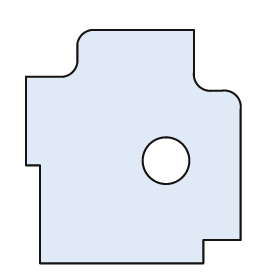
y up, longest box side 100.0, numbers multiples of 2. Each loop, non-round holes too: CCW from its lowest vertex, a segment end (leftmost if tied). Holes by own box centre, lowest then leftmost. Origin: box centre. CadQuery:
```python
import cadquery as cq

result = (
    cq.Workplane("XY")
    .moveTo(-40.0, -50.0)
    .lineTo(30.0, -50.0)
    .lineTo(30.0, -40.0)
    .lineTo(46.0, -40.0)
    .lineTo(46.0, 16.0)
    .threePointArc((44.0, 22.0), (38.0, 24.0))
    .lineTo(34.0, 24.0)
    .threePointArc((28.0, 26.0), (26.0, 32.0))
    .lineTo(26.0, 50.0)
    .lineTo(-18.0, 50.0)
    .threePointArc((-22.0, 48.0), (-24.0, 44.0))
    .lineTo(-24.0, 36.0)
    .threePointArc((-26.0, 32.0), (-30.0, 30.0))
    .lineTo(-46.0, 30.0)
    .lineTo(-46.0, -8.0)
    .lineTo(-40.0, -8.0)
    .close()
    .moveTo(14.0, -6.0)
    .circle(10.0)
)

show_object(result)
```